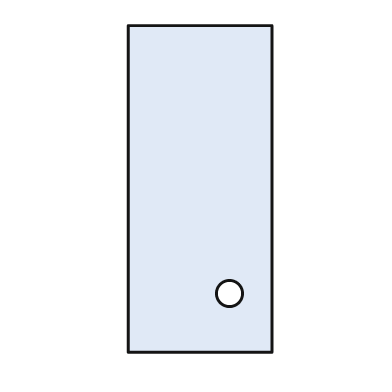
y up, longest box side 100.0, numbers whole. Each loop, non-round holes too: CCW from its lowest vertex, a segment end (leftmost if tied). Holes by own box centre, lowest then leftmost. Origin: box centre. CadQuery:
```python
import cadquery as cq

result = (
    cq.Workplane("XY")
    .moveTo(-22.0, -50.0)
    .lineTo(22.0, -50.0)
    .lineTo(22.0, 50.0)
    .lineTo(-22.0, 50.0)
    .close()
    .moveTo(9.0, -32.0)
    .circle(4.0)
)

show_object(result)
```